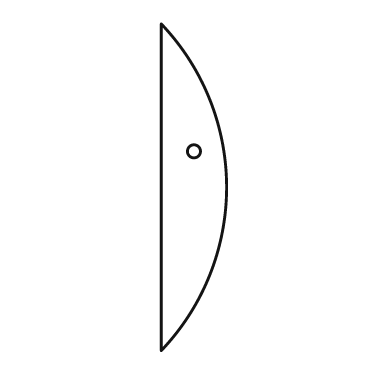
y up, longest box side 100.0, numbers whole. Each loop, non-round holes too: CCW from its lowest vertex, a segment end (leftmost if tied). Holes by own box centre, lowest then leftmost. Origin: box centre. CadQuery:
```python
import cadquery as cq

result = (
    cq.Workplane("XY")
    .moveTo(-10.0, -50.0)
    .threePointArc((10.0, 0.0), (-10.0, 50.0))
    .close()
    .moveTo(0.0, 11.0)
    .circle(2.0)
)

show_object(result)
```